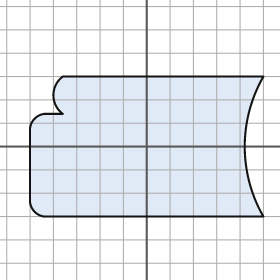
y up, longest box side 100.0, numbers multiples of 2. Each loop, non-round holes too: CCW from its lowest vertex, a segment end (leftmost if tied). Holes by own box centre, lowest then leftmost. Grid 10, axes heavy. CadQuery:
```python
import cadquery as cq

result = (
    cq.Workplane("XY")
    .moveTo(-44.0, -30.0)
    .lineTo(50.0, -30.0)
    .threePointArc((42.0, 0.0), (50.0, 30.0))
    .lineTo(-36.0, 30.0)
    .threePointArc((-40.0, 22.0), (-36.0, 14.0))
    .lineTo(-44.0, 14.0)
    .threePointArc((-48.0, 12.0), (-50.0, 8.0))
    .lineTo(-50.0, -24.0)
    .threePointArc((-48.0, -28.0), (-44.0, -30.0))
    .close()
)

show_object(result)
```